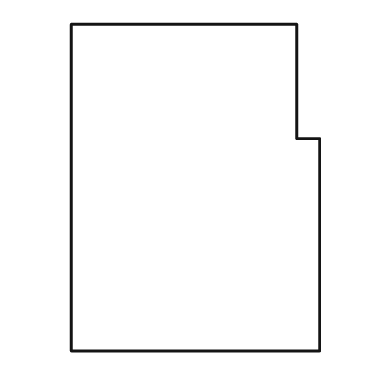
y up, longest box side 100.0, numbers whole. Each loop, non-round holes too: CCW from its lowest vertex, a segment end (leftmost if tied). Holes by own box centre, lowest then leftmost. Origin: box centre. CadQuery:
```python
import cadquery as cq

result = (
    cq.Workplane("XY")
    .moveTo(-38.0, -50.0)
    .lineTo(38.0, -50.0)
    .lineTo(38.0, 15.0)
    .lineTo(31.0, 15.0)
    .lineTo(31.0, 50.0)
    .lineTo(-38.0, 50.0)
    .close()
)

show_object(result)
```